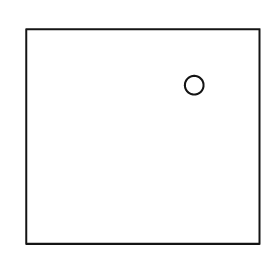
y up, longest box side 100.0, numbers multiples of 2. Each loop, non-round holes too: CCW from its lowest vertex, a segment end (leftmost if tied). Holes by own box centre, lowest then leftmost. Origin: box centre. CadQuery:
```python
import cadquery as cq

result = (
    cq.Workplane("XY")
    .moveTo(-50.0, -46.0)
    .lineTo(50.0, -46.0)
    .lineTo(50.0, 46.0)
    .lineTo(-50.0, 46.0)
    .close()
    .moveTo(22.0, 22.0)
    .circle(4.0)
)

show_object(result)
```